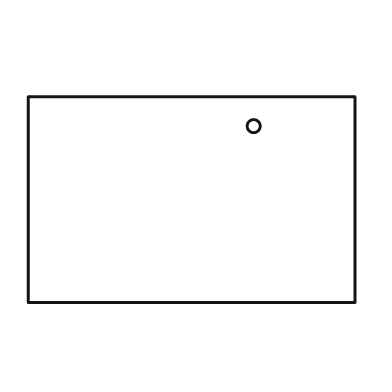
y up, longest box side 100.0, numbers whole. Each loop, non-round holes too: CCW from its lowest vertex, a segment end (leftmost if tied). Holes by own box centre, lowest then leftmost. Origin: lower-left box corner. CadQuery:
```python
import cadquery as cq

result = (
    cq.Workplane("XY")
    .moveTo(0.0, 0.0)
    .lineTo(100.0, 0.0)
    .lineTo(100.0, 63.0)
    .lineTo(0.0, 63.0)
    .close()
    .moveTo(69.0, 54.0)
    .circle(2.0)
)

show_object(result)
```